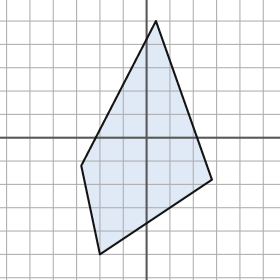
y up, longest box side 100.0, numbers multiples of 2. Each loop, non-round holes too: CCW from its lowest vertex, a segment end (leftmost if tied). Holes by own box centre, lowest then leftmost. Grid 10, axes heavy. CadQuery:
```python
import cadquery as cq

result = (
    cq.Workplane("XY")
    .moveTo(-20.0, -50.0)
    .lineTo(28.0, -18.0)
    .lineTo(4.0, 50.0)
    .lineTo(-28.0, -12.0)
    .close()
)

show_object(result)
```